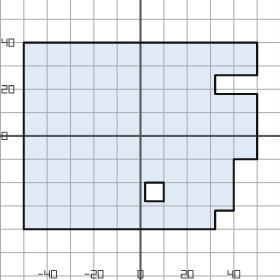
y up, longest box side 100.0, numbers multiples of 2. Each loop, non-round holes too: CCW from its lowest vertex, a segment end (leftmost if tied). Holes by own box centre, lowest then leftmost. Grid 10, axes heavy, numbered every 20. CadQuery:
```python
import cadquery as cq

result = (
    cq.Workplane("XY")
    .moveTo(-50.0, -40.0)
    .lineTo(32.0, -40.0)
    .lineTo(32.0, -32.0)
    .lineTo(40.0, -32.0)
    .lineTo(40.0, -10.0)
    .lineTo(50.0, -10.0)
    .lineTo(50.0, 18.0)
    .lineTo(32.0, 18.0)
    .lineTo(32.0, 26.0)
    .lineTo(50.0, 26.0)
    .lineTo(50.0, 40.0)
    .lineTo(-50.0, 40.0)
    .close()
    .moveTo(2.0, -28.0)
    .lineTo(10.0, -28.0)
    .lineTo(10.0, -20.0)
    .lineTo(2.0, -20.0)
    .close()
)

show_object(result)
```